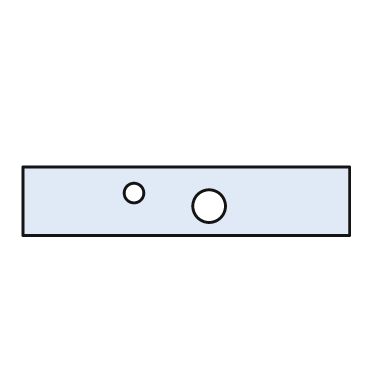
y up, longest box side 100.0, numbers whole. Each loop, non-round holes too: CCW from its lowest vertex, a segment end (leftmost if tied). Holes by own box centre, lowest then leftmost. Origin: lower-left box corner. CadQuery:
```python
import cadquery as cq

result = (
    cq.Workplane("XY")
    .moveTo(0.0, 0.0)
    .lineTo(100.0, 0.0)
    .lineTo(100.0, 21.0)
    .lineTo(0.0, 21.0)
    .close()
    .moveTo(57.0, 9.0)
    .circle(5.0)
    .moveTo(34.0, 13.0)
    .circle(3.0)
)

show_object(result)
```